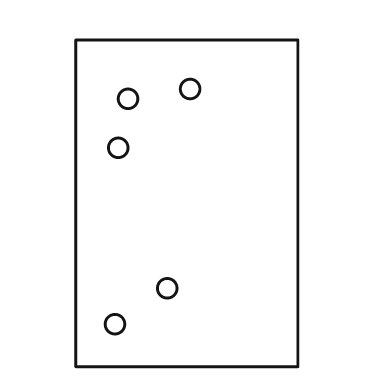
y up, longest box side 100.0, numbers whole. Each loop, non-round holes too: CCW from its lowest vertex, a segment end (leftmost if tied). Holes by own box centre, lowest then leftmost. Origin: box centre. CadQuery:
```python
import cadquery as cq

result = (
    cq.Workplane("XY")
    .moveTo(-34.0, -50.0)
    .lineTo(34.0, -50.0)
    .lineTo(34.0, 50.0)
    .lineTo(-34.0, 50.0)
    .close()
    .moveTo(-22.0, -37.0)
    .circle(3.0)
    .moveTo(-6.0, -26.0)
    .circle(3.0)
    .moveTo(-21.0, 17.0)
    .circle(3.0)
    .moveTo(-18.0, 32.0)
    .circle(3.0)
    .moveTo(1.0, 35.0)
    .circle(3.0)
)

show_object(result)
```